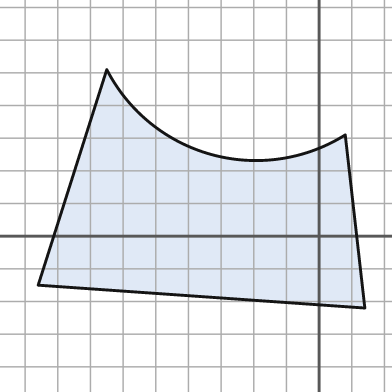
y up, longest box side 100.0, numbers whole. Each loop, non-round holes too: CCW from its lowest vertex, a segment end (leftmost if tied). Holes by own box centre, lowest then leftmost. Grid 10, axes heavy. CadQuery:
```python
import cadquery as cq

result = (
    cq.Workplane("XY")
    .moveTo(14.0, -22.0)
    .lineTo(8.0, 31.0)
    .threePointArc((-33.0, 25.0), (-65.0, 51.0))
    .lineTo(-86.0, -15.0)
    .close()
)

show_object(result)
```